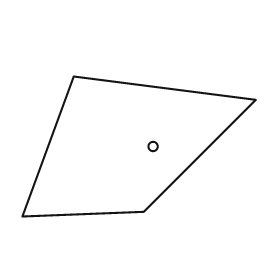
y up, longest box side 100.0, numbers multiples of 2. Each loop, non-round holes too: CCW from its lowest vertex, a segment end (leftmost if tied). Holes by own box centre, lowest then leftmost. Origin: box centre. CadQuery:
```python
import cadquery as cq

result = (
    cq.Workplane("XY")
    .moveTo(-50.0, -30.0)
    .lineTo(2.0, -28.0)
    .lineTo(50.0, 20.0)
    .lineTo(-28.0, 30.0)
    .close()
    .moveTo(6.0, 0.0)
    .circle(2.0)
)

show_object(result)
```